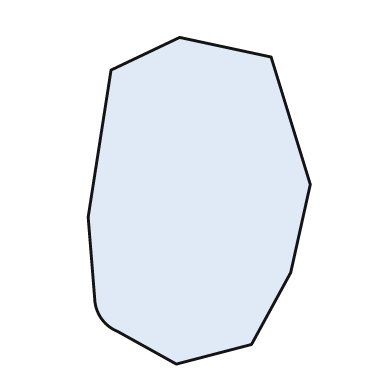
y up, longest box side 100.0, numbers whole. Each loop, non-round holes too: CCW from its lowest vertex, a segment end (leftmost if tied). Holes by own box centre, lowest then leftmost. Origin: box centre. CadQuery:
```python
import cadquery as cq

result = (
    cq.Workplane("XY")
    .moveTo(-7.0, -50.0)
    .lineTo(16.0, -44.0)
    .lineTo(28.0, -22.0)
    .lineTo(34.0, 5.0)
    .lineTo(22.0, 44.0)
    .lineTo(-6.0, 50.0)
    .lineTo(-27.0, 40.0)
    .lineTo(-34.0, -5.0)
    .lineTo(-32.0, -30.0)
    .threePointArc((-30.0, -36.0), (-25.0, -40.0))
    .close()
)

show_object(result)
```